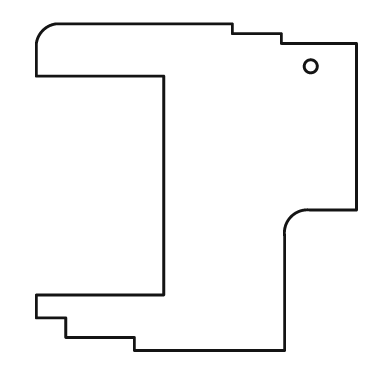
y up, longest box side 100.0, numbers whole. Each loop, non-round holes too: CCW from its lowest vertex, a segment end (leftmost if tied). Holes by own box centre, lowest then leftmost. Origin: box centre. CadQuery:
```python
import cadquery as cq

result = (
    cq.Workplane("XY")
    .moveTo(-19.0, -50.0)
    .lineTo(27.0, -50.0)
    .lineTo(27.0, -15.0)
    .threePointArc((29.0, -9.0), (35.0, -7.0))
    .lineTo(49.0, -7.0)
    .lineTo(49.0, 44.0)
    .lineTo(26.0, 44.0)
    .lineTo(26.0, 47.0)
    .lineTo(11.0, 47.0)
    .lineTo(11.0, 50.0)
    .lineTo(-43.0, 50.0)
    .threePointArc((-47.0, 48.0), (-49.0, 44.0))
    .lineTo(-49.0, 34.0)
    .lineTo(-10.0, 34.0)
    .lineTo(-10.0, -33.0)
    .lineTo(-49.0, -33.0)
    .lineTo(-49.0, -40.0)
    .lineTo(-40.0, -40.0)
    .lineTo(-40.0, -46.0)
    .lineTo(-19.0, -46.0)
    .close()
    .moveTo(35.0, 37.0)
    .circle(2.0)
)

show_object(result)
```